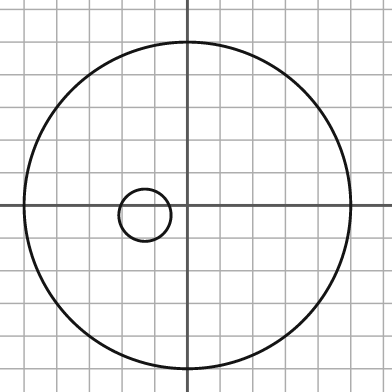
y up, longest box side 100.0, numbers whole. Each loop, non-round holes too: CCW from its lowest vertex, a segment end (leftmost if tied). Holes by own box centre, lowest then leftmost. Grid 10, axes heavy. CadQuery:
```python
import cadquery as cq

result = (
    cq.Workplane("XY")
    .moveTo(0.0, 0.0)
    .circle(50.0)
    .moveTo(-13.0, -3.0)
    .circle(8.0)
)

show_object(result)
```